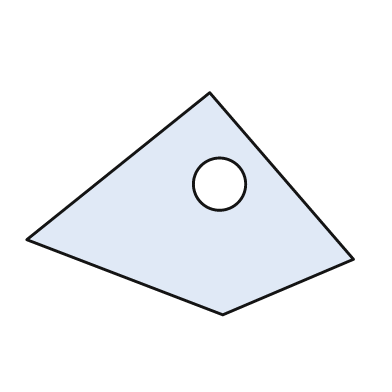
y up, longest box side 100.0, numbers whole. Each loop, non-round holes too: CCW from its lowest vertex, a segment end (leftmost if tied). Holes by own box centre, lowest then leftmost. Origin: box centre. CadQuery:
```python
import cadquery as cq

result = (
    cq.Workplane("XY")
    .moveTo(10.0, -34.0)
    .lineTo(50.0, -17.0)
    .lineTo(6.0, 34.0)
    .lineTo(-50.0, -11.0)
    .close()
    .moveTo(9.0, 6.0)
    .circle(8.0)
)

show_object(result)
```